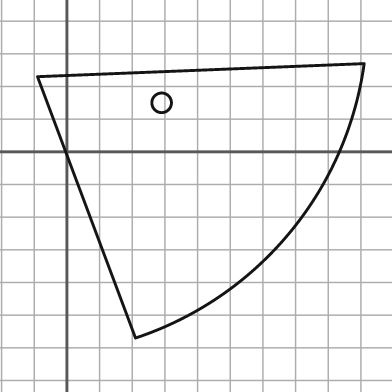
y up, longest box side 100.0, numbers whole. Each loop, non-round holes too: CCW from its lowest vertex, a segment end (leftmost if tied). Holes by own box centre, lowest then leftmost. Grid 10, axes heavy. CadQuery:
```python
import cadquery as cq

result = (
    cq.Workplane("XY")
    .moveTo(21.0, -57.0)
    .threePointArc((68.0, -25.0), (91.0, 27.0))
    .lineTo(-9.0, 23.0)
    .close()
    .moveTo(29.0, 15.0)
    .circle(3.0)
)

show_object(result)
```